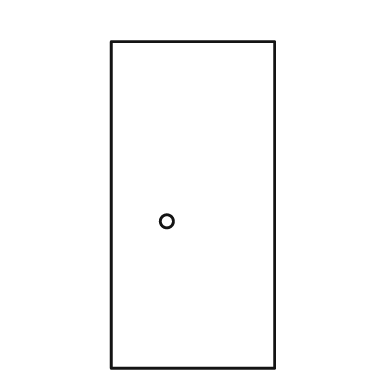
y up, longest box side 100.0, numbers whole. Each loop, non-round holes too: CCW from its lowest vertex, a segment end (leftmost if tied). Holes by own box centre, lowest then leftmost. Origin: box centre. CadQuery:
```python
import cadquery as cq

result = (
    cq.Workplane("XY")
    .moveTo(-25.0, -50.0)
    .lineTo(25.0, -50.0)
    .lineTo(25.0, 50.0)
    .lineTo(-25.0, 50.0)
    .close()
    .moveTo(-8.0, -5.0)
    .circle(2.0)
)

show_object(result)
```